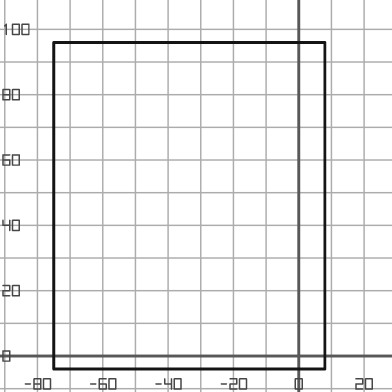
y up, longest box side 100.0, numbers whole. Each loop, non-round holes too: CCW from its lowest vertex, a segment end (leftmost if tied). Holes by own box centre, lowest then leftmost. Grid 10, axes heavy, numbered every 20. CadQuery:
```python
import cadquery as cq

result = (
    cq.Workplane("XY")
    .moveTo(-75.0, -4.0)
    .lineTo(8.0, -4.0)
    .lineTo(8.0, 96.0)
    .lineTo(-75.0, 96.0)
    .close()
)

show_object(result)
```